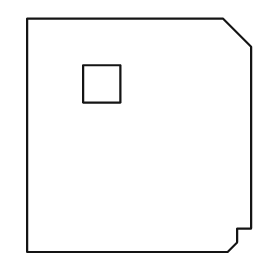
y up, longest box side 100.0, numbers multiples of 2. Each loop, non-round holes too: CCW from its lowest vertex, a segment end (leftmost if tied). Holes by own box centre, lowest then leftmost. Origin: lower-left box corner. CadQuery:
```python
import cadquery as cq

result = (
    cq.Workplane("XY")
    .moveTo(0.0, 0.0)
    .lineTo(86.0, 0.0)
    .lineTo(90.0, 4.0)
    .lineTo(90.0, 10.0)
    .lineTo(96.0, 10.0)
    .lineTo(96.0, 88.0)
    .lineTo(84.0, 100.0)
    .lineTo(0.0, 100.0)
    .close()
    .moveTo(24.0, 64.0)
    .lineTo(40.0, 64.0)
    .lineTo(40.0, 80.0)
    .lineTo(24.0, 80.0)
    .close()
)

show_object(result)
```